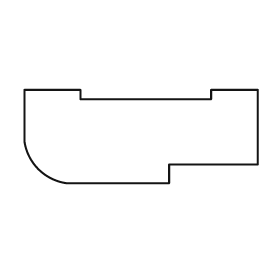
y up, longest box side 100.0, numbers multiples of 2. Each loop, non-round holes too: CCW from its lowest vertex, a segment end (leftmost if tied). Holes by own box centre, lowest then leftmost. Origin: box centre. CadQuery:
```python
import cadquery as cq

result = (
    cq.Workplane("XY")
    .moveTo(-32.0, -20.0)
    .lineTo(12.0, -20.0)
    .lineTo(12.0, -12.0)
    .lineTo(50.0, -12.0)
    .lineTo(50.0, 20.0)
    .lineTo(30.0, 20.0)
    .lineTo(30.0, 16.0)
    .lineTo(-26.0, 16.0)
    .lineTo(-26.0, 20.0)
    .lineTo(-50.0, 20.0)
    .lineTo(-50.0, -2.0)
    .threePointArc((-44.0, -14.0), (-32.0, -20.0))
    .close()
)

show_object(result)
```